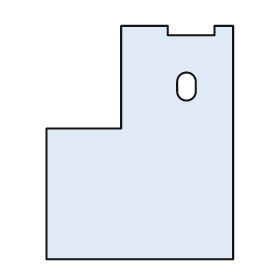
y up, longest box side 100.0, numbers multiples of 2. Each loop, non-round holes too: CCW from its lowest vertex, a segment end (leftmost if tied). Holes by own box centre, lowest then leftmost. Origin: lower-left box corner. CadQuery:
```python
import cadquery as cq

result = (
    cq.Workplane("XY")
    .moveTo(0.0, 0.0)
    .lineTo(80.0, 0.0)
    .lineTo(80.0, 100.0)
    .lineTo(72.0, 100.0)
    .lineTo(72.0, 96.0)
    .lineTo(52.0, 96.0)
    .lineTo(52.0, 100.0)
    .lineTo(32.0, 100.0)
    .lineTo(32.0, 56.0)
    .lineTo(0.0, 56.0)
    .close()
    .moveTo(56.0, 72.0)
    .threePointArc((60.0, 68.0), (64.0, 72.0))
    .lineTo(64.0, 76.0)
    .threePointArc((60.0, 80.0), (56.0, 76.0))
    .close()
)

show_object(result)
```